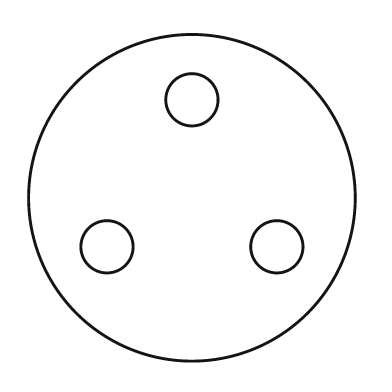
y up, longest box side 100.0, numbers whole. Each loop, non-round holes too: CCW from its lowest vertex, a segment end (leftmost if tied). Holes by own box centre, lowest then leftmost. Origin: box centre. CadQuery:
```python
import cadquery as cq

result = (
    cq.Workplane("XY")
    .moveTo(0.0, 0.0)
    .circle(50.0)
    .moveTo(-26.0, -15.0)
    .circle(8.0)
    .moveTo(26.0, -15.0)
    .circle(8.0)
    .moveTo(0.0, 30.0)
    .circle(8.0)
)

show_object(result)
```